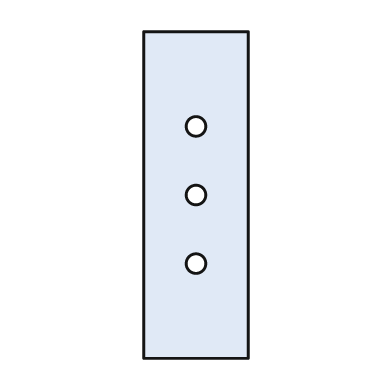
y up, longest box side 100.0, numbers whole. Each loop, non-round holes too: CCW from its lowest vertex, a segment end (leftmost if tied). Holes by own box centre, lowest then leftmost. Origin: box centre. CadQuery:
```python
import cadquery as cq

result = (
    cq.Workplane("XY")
    .moveTo(-16.0, -50.0)
    .lineTo(16.0, -50.0)
    .lineTo(16.0, 50.0)
    .lineTo(-16.0, 50.0)
    .close()
    .moveTo(0.0, -21.0)
    .circle(3.0)
    .moveTo(0.0, 0.0)
    .circle(3.0)
    .moveTo(0.0, 21.0)
    .circle(3.0)
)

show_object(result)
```